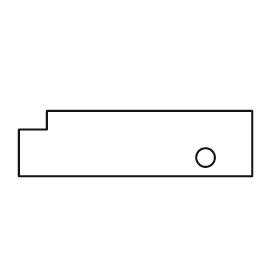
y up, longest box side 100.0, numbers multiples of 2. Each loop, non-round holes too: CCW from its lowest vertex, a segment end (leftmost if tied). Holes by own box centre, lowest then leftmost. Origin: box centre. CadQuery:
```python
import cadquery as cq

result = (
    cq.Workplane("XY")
    .moveTo(-50.0, -14.0)
    .lineTo(50.0, -14.0)
    .lineTo(50.0, 14.0)
    .lineTo(-38.0, 14.0)
    .lineTo(-38.0, 6.0)
    .lineTo(-50.0, 6.0)
    .close()
    .moveTo(30.0, -6.0)
    .circle(4.0)
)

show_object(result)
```